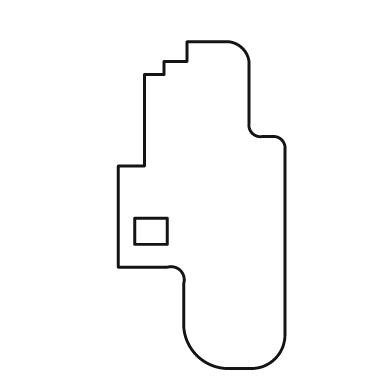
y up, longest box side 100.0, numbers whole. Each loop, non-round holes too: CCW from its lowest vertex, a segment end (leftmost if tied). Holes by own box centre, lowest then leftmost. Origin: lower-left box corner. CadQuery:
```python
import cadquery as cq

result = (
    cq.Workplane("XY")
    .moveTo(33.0, 0.0)
    .lineTo(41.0, 0.0)
    .threePointArc((48.0, 3.0), (51.0, 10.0))
    .lineTo(51.0, 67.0)
    .threePointArc((50.0, 70.0), (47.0, 71.0))
    .lineTo(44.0, 71.0)
    .threePointArc((41.0, 72.0), (40.0, 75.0))
    .lineTo(40.0, 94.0)
    .threePointArc((38.0, 98.0), (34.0, 100.0))
    .lineTo(21.0, 100.0)
    .lineTo(21.0, 94.0)
    .lineTo(14.0, 94.0)
    .lineTo(14.0, 90.0)
    .lineTo(8.0, 90.0)
    .lineTo(8.0, 62.0)
    .lineTo(0.0, 62.0)
    .lineTo(0.0, 31.0)
    .lineTo(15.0, 31.0)
    .threePointArc((19.0, 30.0), (20.0, 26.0))
    .lineTo(20.0, 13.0)
    .threePointArc((24.0, 4.0), (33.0, 0.0))
    .close()
    .moveTo(5.0, 38.0)
    .lineTo(15.0, 38.0)
    .lineTo(15.0, 46.0)
    .lineTo(5.0, 46.0)
    .close()
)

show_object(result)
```